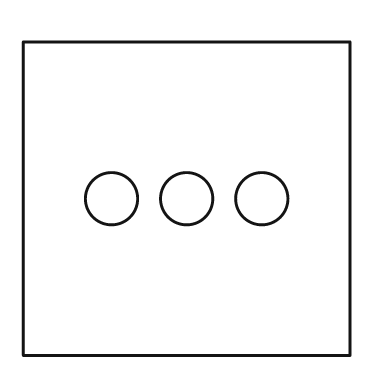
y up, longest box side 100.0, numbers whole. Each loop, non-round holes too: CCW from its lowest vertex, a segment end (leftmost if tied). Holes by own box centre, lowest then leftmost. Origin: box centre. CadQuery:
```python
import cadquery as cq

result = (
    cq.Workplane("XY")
    .moveTo(-50.0, -48.0)
    .lineTo(50.0, -48.0)
    .lineTo(50.0, 48.0)
    .lineTo(-50.0, 48.0)
    .close()
    .moveTo(-23.0, 0.0)
    .circle(8.0)
    .moveTo(0.0, 0.0)
    .circle(8.0)
    .moveTo(23.0, 0.0)
    .circle(8.0)
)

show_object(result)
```